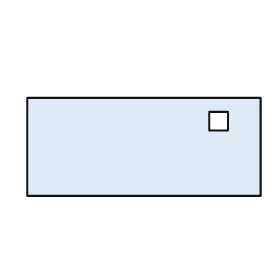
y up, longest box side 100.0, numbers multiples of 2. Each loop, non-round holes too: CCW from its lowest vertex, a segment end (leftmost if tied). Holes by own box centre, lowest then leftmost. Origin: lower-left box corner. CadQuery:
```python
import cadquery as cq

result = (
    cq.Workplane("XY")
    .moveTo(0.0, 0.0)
    .lineTo(100.0, 0.0)
    .lineTo(100.0, 42.0)
    .lineTo(0.0, 42.0)
    .close()
    .moveTo(78.0, 28.0)
    .lineTo(86.0, 28.0)
    .lineTo(86.0, 36.0)
    .lineTo(78.0, 36.0)
    .close()
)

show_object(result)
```